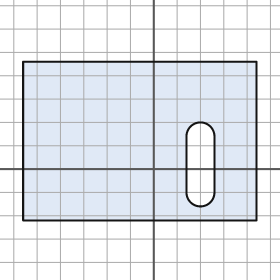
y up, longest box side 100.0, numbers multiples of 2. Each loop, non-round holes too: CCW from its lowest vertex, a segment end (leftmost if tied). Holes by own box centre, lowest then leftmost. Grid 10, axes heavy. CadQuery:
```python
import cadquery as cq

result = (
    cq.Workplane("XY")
    .moveTo(-56.0, -22.0)
    .lineTo(44.0, -22.0)
    .lineTo(44.0, 46.0)
    .lineTo(-56.0, 46.0)
    .close()
    .moveTo(14.0, -10.0)
    .threePointArc((20.0, -16.0), (26.0, -10.0))
    .lineTo(26.0, 14.0)
    .threePointArc((20.0, 20.0), (14.0, 14.0))
    .close()
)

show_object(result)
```